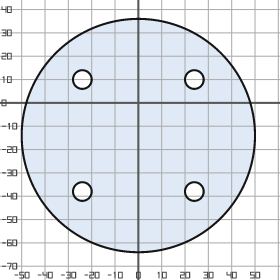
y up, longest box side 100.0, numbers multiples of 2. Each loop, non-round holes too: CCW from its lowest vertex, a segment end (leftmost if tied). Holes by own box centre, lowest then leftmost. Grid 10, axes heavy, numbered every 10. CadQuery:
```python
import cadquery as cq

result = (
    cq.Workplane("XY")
    .moveTo(0.0, -14.0)
    .circle(50.0)
    .moveTo(-24.0, -38.0)
    .circle(4.0)
    .moveTo(24.0, -38.0)
    .circle(4.0)
    .moveTo(-24.0, 10.0)
    .circle(4.0)
    .moveTo(24.0, 10.0)
    .circle(4.0)
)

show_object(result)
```